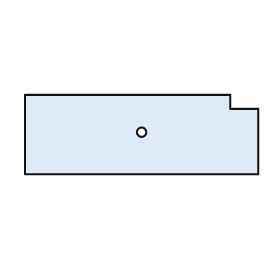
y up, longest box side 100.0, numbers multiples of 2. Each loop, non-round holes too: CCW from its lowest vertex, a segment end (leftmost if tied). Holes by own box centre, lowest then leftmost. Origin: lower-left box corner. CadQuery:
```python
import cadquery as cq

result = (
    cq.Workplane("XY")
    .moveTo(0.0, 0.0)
    .lineTo(100.0, 0.0)
    .lineTo(100.0, 28.0)
    .lineTo(88.0, 28.0)
    .lineTo(88.0, 34.0)
    .lineTo(0.0, 34.0)
    .close()
    .moveTo(50.0, 18.0)
    .circle(2.0)
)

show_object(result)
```